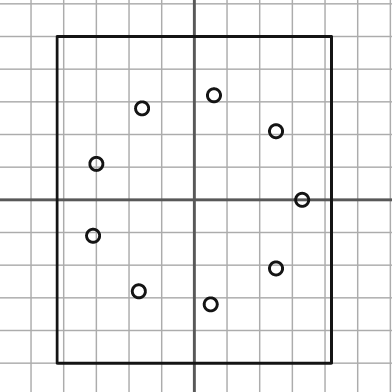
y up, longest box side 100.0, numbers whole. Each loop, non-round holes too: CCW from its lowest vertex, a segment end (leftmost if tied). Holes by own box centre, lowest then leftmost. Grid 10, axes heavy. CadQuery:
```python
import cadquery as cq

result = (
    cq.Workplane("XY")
    .moveTo(-42.0, -50.0)
    .lineTo(42.0, -50.0)
    .lineTo(42.0, 50.0)
    .lineTo(-42.0, 50.0)
    .close()
    .moveTo(5.0, -32.0)
    .circle(2.0)
    .moveTo(-17.0, -28.0)
    .circle(2.0)
    .moveTo(25.0, -21.0)
    .circle(2.0)
    .moveTo(-31.0, -11.0)
    .circle(2.0)
    .moveTo(33.0, 0.0)
    .circle(2.0)
    .moveTo(-30.0, 11.0)
    .circle(2.0)
    .moveTo(25.0, 21.0)
    .circle(2.0)
    .moveTo(-16.0, 28.0)
    .circle(2.0)
    .moveTo(6.0, 32.0)
    .circle(2.0)
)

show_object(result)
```